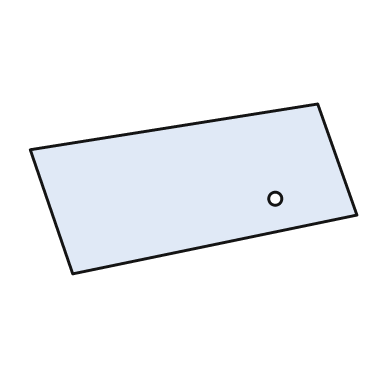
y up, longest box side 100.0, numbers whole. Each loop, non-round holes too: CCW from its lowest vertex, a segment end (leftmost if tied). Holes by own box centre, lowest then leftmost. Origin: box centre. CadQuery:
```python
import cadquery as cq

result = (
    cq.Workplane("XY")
    .moveTo(-37.0, -26.0)
    .lineTo(50.0, -8.0)
    .lineTo(38.0, 26.0)
    .lineTo(-50.0, 12.0)
    .close()
    .moveTo(25.0, -3.0)
    .circle(2.0)
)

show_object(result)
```